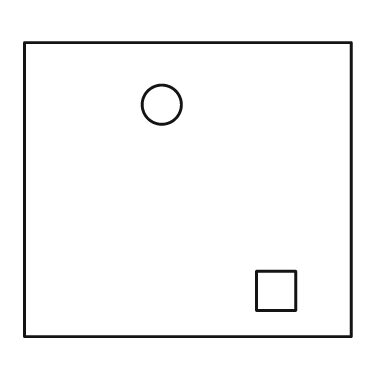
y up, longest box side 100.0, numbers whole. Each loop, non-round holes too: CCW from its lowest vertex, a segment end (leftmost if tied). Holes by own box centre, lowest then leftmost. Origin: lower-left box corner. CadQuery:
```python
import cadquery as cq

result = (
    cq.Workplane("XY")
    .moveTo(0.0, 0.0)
    .lineTo(100.0, 0.0)
    .lineTo(100.0, 90.0)
    .lineTo(0.0, 90.0)
    .close()
    .moveTo(71.0, 8.0)
    .lineTo(83.0, 8.0)
    .lineTo(83.0, 20.0)
    .lineTo(71.0, 20.0)
    .close()
    .moveTo(42.0, 71.0)
    .circle(6.0)
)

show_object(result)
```